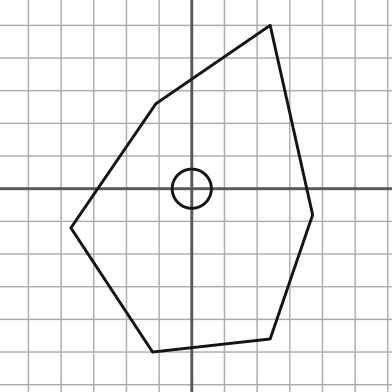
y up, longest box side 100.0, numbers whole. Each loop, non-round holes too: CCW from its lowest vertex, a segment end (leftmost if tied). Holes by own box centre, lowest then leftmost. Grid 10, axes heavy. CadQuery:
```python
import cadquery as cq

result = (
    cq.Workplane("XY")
    .moveTo(-12.0, -50.0)
    .lineTo(24.0, -46.0)
    .lineTo(37.0, -8.0)
    .lineTo(24.0, 50.0)
    .lineTo(-11.0, 26.0)
    .lineTo(-37.0, -12.0)
    .close()
    .moveTo(0.0, 0.0)
    .circle(6.0)
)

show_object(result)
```